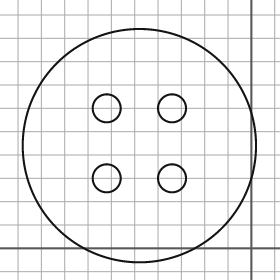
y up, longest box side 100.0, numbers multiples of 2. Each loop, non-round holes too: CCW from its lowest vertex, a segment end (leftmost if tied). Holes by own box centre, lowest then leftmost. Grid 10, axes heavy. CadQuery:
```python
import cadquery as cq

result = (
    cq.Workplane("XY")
    .moveTo(-48.0, 44.0)
    .circle(50.0)
    .moveTo(-62.0, 30.0)
    .circle(6.0)
    .moveTo(-34.0, 30.0)
    .circle(6.0)
    .moveTo(-62.0, 60.0)
    .circle(6.0)
    .moveTo(-34.0, 60.0)
    .circle(6.0)
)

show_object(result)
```